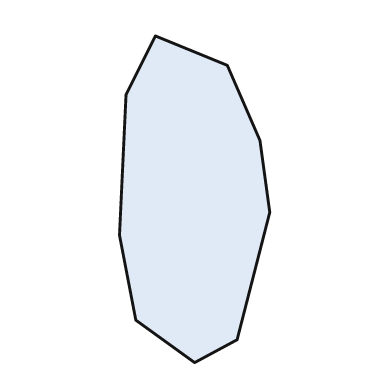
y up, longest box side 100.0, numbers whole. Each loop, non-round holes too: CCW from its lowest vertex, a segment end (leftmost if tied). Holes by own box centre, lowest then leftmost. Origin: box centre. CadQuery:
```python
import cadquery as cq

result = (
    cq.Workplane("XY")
    .moveTo(0.0, -50.0)
    .lineTo(13.0, -43.0)
    .lineTo(23.0, -4.0)
    .lineTo(20.0, 18.0)
    .lineTo(10.0, 41.0)
    .lineTo(-12.0, 50.0)
    .lineTo(-21.0, 32.0)
    .lineTo(-23.0, -11.0)
    .lineTo(-18.0, -37.0)
    .close()
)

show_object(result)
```